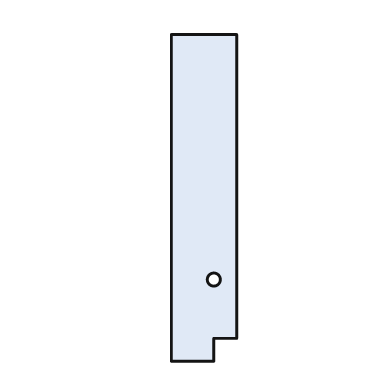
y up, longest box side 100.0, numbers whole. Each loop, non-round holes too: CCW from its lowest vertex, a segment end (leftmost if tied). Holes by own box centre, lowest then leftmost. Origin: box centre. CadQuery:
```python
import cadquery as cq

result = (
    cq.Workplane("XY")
    .moveTo(-10.0, -50.0)
    .lineTo(3.0, -50.0)
    .lineTo(3.0, -43.0)
    .lineTo(10.0, -43.0)
    .lineTo(10.0, 50.0)
    .lineTo(-10.0, 50.0)
    .close()
    .moveTo(3.0, -25.0)
    .circle(2.0)
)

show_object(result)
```